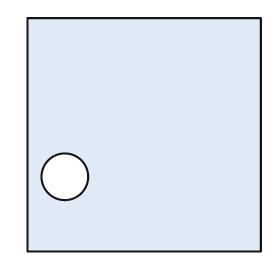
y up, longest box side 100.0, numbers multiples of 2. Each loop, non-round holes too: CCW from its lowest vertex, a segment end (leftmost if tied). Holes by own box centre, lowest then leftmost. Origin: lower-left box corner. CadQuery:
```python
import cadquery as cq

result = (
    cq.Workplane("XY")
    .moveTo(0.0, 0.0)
    .lineTo(100.0, 0.0)
    .lineTo(100.0, 100.0)
    .lineTo(0.0, 100.0)
    .close()
    .moveTo(16.0, 32.0)
    .circle(10.0)
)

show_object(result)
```